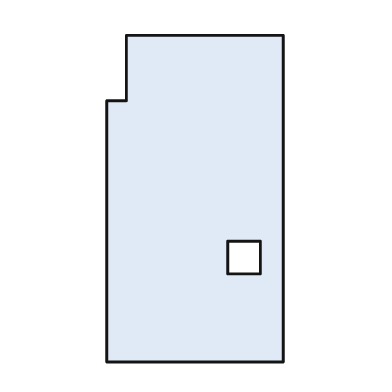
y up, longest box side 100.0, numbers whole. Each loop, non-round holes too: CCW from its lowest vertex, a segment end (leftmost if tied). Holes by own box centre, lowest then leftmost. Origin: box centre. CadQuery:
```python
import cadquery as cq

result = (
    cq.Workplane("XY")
    .moveTo(-27.0, -50.0)
    .lineTo(27.0, -50.0)
    .lineTo(27.0, 50.0)
    .lineTo(-21.0, 50.0)
    .lineTo(-21.0, 30.0)
    .lineTo(-27.0, 30.0)
    .close()
    .moveTo(10.0, -23.0)
    .lineTo(20.0, -23.0)
    .lineTo(20.0, -13.0)
    .lineTo(10.0, -13.0)
    .close()
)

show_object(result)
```